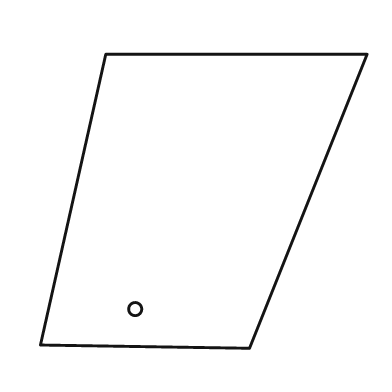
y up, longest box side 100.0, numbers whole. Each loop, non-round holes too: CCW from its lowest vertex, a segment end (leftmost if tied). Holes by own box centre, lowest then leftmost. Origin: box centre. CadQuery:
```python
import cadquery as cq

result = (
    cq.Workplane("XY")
    .moveTo(14.0, -45.0)
    .lineTo(50.0, 45.0)
    .lineTo(-30.0, 45.0)
    .lineTo(-50.0, -44.0)
    .close()
    .moveTo(-21.0, -33.0)
    .circle(2.0)
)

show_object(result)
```